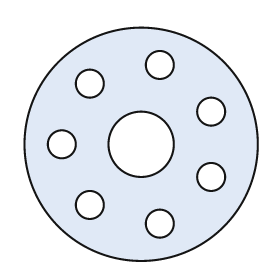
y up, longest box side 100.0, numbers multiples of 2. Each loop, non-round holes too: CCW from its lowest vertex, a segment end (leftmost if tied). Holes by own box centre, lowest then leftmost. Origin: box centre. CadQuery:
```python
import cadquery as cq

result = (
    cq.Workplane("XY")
    .moveTo(0.0, 0.0)
    .circle(50.0)
    .moveTo(8.0, -34.0)
    .circle(6.0)
    .moveTo(-22.0, -26.0)
    .circle(6.0)
    .moveTo(30.0, -14.0)
    .circle(6.0)
    .moveTo(-34.0, 0.0)
    .circle(6.0)
    .moveTo(0.0, 0.0)
    .circle(14.0)
    .moveTo(30.0, 14.0)
    .circle(6.0)
    .moveTo(-22.0, 26.0)
    .circle(6.0)
    .moveTo(8.0, 34.0)
    .circle(6.0)
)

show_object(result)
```